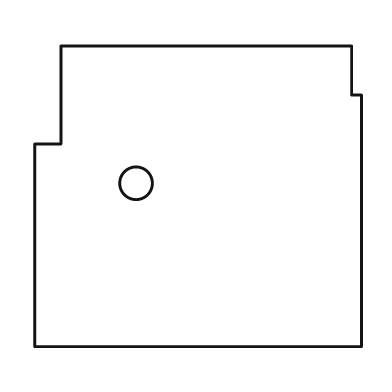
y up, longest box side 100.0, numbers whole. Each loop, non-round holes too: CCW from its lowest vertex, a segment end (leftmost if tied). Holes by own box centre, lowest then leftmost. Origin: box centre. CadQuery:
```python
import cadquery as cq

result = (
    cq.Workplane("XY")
    .moveTo(-50.0, -46.0)
    .lineTo(50.0, -46.0)
    .lineTo(50.0, 31.0)
    .lineTo(47.0, 31.0)
    .lineTo(47.0, 46.0)
    .lineTo(-42.0, 46.0)
    .lineTo(-42.0, 16.0)
    .lineTo(-50.0, 16.0)
    .close()
    .moveTo(-19.0, 4.0)
    .circle(5.0)
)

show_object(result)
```